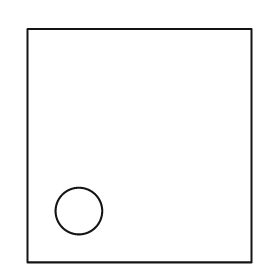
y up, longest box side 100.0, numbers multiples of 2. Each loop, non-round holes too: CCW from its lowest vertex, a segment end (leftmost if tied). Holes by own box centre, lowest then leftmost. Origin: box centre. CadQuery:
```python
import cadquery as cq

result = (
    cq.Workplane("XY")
    .moveTo(-48.0, -50.0)
    .lineTo(48.0, -50.0)
    .lineTo(48.0, 50.0)
    .lineTo(-48.0, 50.0)
    .close()
    .moveTo(-26.0, -28.0)
    .circle(10.0)
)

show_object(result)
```